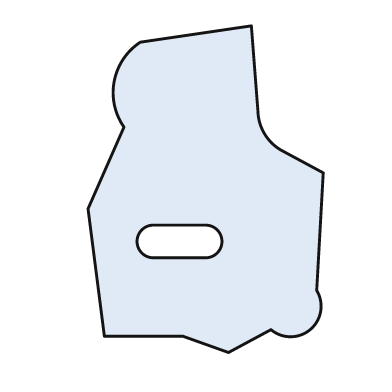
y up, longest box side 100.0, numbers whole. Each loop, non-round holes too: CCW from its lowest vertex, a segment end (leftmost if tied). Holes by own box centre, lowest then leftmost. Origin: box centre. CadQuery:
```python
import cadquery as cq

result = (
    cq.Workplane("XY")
    .moveTo(7.0, -50.0)
    .lineTo(20.0, -43.0)
    .threePointArc((32.0, -43.0), (34.0, -31.0))
    .lineTo(36.0, 5.0)
    .lineTo(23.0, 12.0)
    .threePointArc((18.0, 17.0), (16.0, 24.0))
    .lineTo(14.0, 50.0)
    .lineTo(-20.0, 45.0)
    .threePointArc((-28.0, 33.0), (-25.0, 19.0))
    .lineTo(-36.0, -6.0)
    .lineTo(-31.0, -45.0)
    .lineTo(-7.0, -45.0)
    .close()
    .moveTo(-16.0, -21.0)
    .lineTo(0.0, -21.0)
    .threePointArc((5.0, -16.0), (0.0, -11.0))
    .lineTo(-16.0, -11.0)
    .threePointArc((-21.0, -16.0), (-16.0, -21.0))
    .close()
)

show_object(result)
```